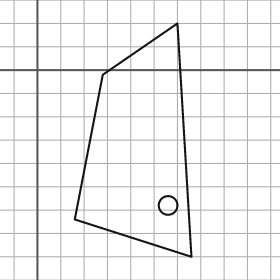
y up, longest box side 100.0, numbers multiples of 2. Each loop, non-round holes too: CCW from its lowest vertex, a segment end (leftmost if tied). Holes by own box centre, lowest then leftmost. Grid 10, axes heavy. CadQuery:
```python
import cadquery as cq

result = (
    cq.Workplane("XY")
    .moveTo(66.0, -80.0)
    .lineTo(60.0, 20.0)
    .lineTo(28.0, -2.0)
    .lineTo(16.0, -64.0)
    .close()
    .moveTo(56.0, -58.0)
    .circle(4.0)
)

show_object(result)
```